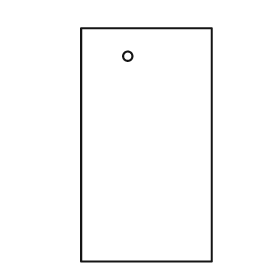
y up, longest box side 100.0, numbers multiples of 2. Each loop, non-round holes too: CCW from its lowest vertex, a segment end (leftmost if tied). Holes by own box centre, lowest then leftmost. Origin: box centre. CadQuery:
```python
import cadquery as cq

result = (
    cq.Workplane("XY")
    .moveTo(-28.0, -50.0)
    .lineTo(28.0, -50.0)
    .lineTo(28.0, 50.0)
    .lineTo(-28.0, 50.0)
    .close()
    .moveTo(-8.0, 38.0)
    .circle(2.0)
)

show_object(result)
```